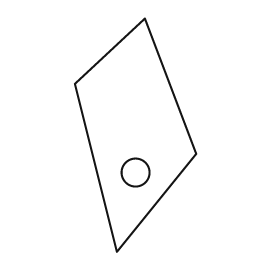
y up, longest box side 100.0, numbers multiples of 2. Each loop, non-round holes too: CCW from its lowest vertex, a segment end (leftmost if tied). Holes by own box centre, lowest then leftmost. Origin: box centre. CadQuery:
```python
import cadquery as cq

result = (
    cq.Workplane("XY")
    .moveTo(-8.0, -50.0)
    .lineTo(26.0, -8.0)
    .lineTo(4.0, 50.0)
    .lineTo(-26.0, 22.0)
    .close()
    .moveTo(0.0, -16.0)
    .circle(6.0)
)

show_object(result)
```